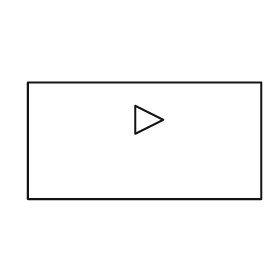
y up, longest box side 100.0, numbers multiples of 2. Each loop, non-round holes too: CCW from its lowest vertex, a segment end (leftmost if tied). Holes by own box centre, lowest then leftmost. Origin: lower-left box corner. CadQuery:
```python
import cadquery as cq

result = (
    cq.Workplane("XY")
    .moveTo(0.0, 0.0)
    .lineTo(100.0, 0.0)
    .lineTo(100.0, 50.0)
    .lineTo(0.0, 50.0)
    .close()
    .moveTo(46.0, 28.0)
    .lineTo(58.0, 34.0)
    .lineTo(46.0, 40.0)
    .close()
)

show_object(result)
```